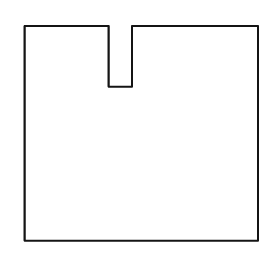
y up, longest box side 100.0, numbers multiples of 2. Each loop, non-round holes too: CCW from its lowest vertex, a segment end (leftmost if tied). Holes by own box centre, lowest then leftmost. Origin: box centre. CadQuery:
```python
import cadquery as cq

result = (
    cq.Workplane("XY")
    .moveTo(-50.0, -46.0)
    .lineTo(50.0, -46.0)
    .lineTo(50.0, 46.0)
    .lineTo(-4.0, 46.0)
    .lineTo(-4.0, 20.0)
    .lineTo(-14.0, 20.0)
    .lineTo(-14.0, 46.0)
    .lineTo(-50.0, 46.0)
    .close()
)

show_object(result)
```